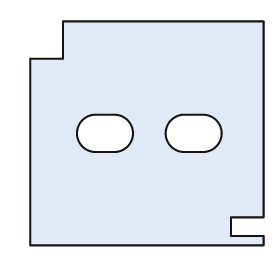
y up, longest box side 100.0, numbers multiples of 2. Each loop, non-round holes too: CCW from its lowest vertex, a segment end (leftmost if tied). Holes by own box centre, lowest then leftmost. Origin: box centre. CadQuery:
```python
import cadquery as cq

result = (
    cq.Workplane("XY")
    .moveTo(-50.0, -48.0)
    .lineTo(50.0, -48.0)
    .lineTo(50.0, -44.0)
    .lineTo(36.0, -44.0)
    .lineTo(36.0, -36.0)
    .lineTo(50.0, -36.0)
    .lineTo(50.0, 48.0)
    .lineTo(-36.0, 48.0)
    .lineTo(-36.0, 32.0)
    .lineTo(-50.0, 32.0)
    .close()
    .moveTo(-22.0, -8.0)
    .lineTo(-14.0, -8.0)
    .threePointArc((-6.0, 0.0), (-14.0, 8.0))
    .lineTo(-22.0, 8.0)
    .threePointArc((-30.0, 0.0), (-22.0, -8.0))
    .close()
    .moveTo(16.0, -8.0)
    .lineTo(24.0, -8.0)
    .threePointArc((32.0, 0.0), (24.0, 8.0))
    .lineTo(16.0, 8.0)
    .threePointArc((8.0, 0.0), (16.0, -8.0))
    .close()
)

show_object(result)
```